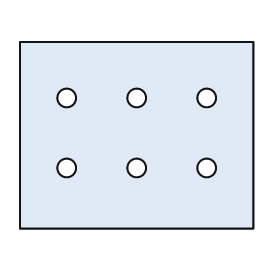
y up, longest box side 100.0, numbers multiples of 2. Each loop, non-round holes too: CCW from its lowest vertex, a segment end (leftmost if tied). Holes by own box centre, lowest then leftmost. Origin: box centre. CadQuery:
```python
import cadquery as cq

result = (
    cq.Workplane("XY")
    .moveTo(-50.0, -40.0)
    .lineTo(50.0, -40.0)
    .lineTo(50.0, 40.0)
    .lineTo(-50.0, 40.0)
    .close()
    .moveTo(-30.0, -14.0)
    .circle(4.0)
    .moveTo(0.0, -14.0)
    .circle(4.0)
    .moveTo(30.0, -14.0)
    .circle(4.0)
    .moveTo(-30.0, 16.0)
    .circle(4.0)
    .moveTo(0.0, 16.0)
    .circle(4.0)
    .moveTo(30.0, 16.0)
    .circle(4.0)
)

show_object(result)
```